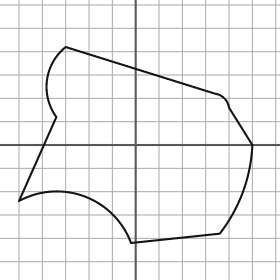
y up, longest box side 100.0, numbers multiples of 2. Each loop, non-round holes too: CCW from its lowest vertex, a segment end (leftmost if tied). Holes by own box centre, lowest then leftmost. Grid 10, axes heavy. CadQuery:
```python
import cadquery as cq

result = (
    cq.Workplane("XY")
    .moveTo(-2.0, -42.0)
    .lineTo(36.0, -38.0)
    .threePointArc((46.0, -20.0), (50.0, 0.0))
    .lineTo(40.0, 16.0)
    .threePointArc((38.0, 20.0), (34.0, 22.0))
    .lineTo(-30.0, 42.0)
    .threePointArc((-38.0, 28.0), (-34.0, 12.0))
    .lineTo(-50.0, -24.0)
    .threePointArc((-22.0, -22.0), (-2.0, -42.0))
    .close()
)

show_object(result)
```